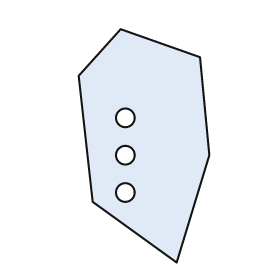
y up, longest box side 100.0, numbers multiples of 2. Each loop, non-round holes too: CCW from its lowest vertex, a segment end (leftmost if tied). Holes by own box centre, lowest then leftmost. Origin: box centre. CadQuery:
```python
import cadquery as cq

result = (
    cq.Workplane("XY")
    .moveTo(14.0, -50.0)
    .lineTo(28.0, -4.0)
    .lineTo(24.0, 38.0)
    .lineTo(-10.0, 50.0)
    .lineTo(-28.0, 30.0)
    .lineTo(-22.0, -24.0)
    .close()
    .moveTo(-8.0, -20.0)
    .circle(4.0)
    .moveTo(-8.0, -4.0)
    .circle(4.0)
    .moveTo(-8.0, 12.0)
    .circle(4.0)
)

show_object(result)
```